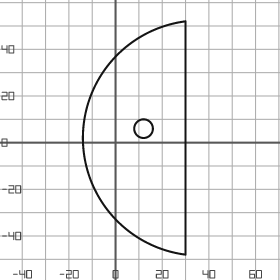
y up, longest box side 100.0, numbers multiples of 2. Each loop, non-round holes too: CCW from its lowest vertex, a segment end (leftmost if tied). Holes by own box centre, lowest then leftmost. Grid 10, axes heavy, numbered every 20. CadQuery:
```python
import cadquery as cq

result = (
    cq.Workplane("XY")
    .moveTo(30.0, -48.0)
    .lineTo(30.0, 52.0)
    .threePointArc((-14.0, 2.0), (30.0, -48.0))
    .close()
    .moveTo(12.0, 6.0)
    .circle(4.0)
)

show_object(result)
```